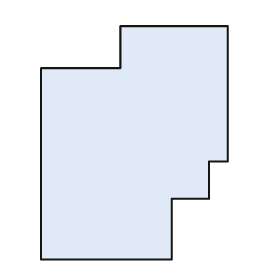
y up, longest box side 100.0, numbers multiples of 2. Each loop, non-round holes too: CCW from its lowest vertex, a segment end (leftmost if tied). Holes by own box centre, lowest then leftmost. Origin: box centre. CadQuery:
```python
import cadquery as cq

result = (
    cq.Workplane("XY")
    .moveTo(-40.0, -50.0)
    .lineTo(16.0, -50.0)
    .lineTo(16.0, -24.0)
    .lineTo(32.0, -24.0)
    .lineTo(32.0, -8.0)
    .lineTo(40.0, -8.0)
    .lineTo(40.0, 50.0)
    .lineTo(-6.0, 50.0)
    .lineTo(-6.0, 32.0)
    .lineTo(-40.0, 32.0)
    .close()
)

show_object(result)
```